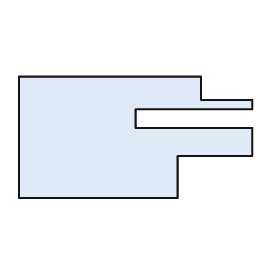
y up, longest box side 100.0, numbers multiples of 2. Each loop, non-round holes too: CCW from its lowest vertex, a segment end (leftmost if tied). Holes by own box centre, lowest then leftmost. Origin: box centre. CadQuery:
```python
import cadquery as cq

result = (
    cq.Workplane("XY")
    .moveTo(-50.0, -26.0)
    .lineTo(18.0, -26.0)
    .lineTo(18.0, -8.0)
    .lineTo(50.0, -8.0)
    .lineTo(50.0, 4.0)
    .lineTo(0.0, 4.0)
    .lineTo(0.0, 12.0)
    .lineTo(50.0, 12.0)
    .lineTo(50.0, 16.0)
    .lineTo(28.0, 16.0)
    .lineTo(28.0, 26.0)
    .lineTo(-50.0, 26.0)
    .close()
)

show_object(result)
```